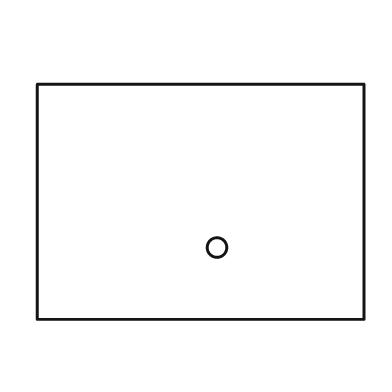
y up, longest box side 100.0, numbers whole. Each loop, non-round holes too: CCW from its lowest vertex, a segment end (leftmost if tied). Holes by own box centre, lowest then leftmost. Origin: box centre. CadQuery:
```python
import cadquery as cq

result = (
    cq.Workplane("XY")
    .moveTo(-50.0, -36.0)
    .lineTo(50.0, -36.0)
    .lineTo(50.0, 36.0)
    .lineTo(-50.0, 36.0)
    .close()
    .moveTo(5.0, -14.0)
    .circle(3.0)
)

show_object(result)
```